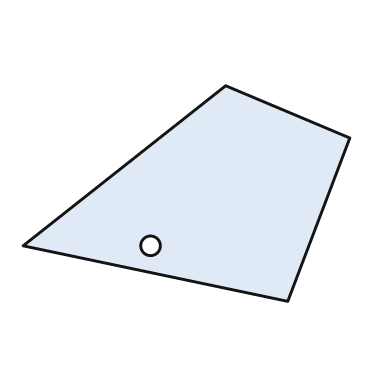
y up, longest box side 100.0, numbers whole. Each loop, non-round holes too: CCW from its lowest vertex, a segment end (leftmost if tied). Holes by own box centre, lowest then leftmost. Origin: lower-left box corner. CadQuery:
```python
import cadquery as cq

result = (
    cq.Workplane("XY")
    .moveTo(81.0, 0.0)
    .lineTo(100.0, 50.0)
    .lineTo(62.0, 66.0)
    .lineTo(0.0, 17.0)
    .close()
    .moveTo(39.0, 17.0)
    .circle(3.0)
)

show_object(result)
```